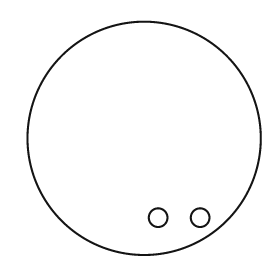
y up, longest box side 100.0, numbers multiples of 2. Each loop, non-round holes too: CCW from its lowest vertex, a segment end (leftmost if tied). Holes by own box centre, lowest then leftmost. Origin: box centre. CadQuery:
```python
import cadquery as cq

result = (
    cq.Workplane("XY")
    .moveTo(0.0, 0.0)
    .circle(50.0)
    .moveTo(6.0, -34.0)
    .circle(4.0)
    .moveTo(24.0, -34.0)
    .circle(4.0)
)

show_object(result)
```